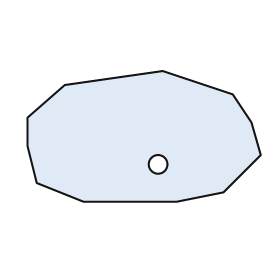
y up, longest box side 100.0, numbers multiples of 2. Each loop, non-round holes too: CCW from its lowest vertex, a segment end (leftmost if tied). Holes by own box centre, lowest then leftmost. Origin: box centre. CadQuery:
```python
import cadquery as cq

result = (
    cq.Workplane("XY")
    .moveTo(-26.0, -28.0)
    .lineTo(14.0, -28.0)
    .lineTo(34.0, -24.0)
    .lineTo(50.0, -8.0)
    .lineTo(46.0, 6.0)
    .lineTo(38.0, 18.0)
    .lineTo(8.0, 28.0)
    .lineTo(-34.0, 22.0)
    .lineTo(-50.0, 8.0)
    .lineTo(-50.0, -4.0)
    .lineTo(-46.0, -20.0)
    .close()
    .moveTo(6.0, -12.0)
    .circle(4.0)
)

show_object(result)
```